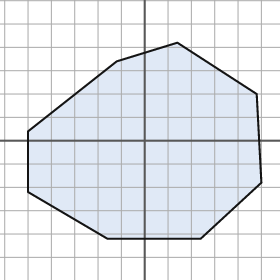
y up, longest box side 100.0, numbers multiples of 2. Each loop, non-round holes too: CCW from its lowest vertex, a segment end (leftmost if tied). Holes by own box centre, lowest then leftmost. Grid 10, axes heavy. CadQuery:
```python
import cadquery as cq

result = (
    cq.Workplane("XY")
    .moveTo(-16.0, -42.0)
    .lineTo(24.0, -42.0)
    .lineTo(50.0, -18.0)
    .lineTo(48.0, 20.0)
    .lineTo(14.0, 42.0)
    .lineTo(-12.0, 34.0)
    .lineTo(-50.0, 4.0)
    .lineTo(-50.0, -22.0)
    .close()
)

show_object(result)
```